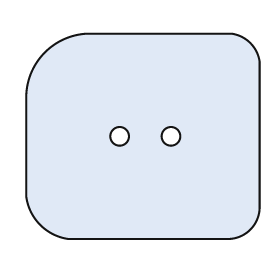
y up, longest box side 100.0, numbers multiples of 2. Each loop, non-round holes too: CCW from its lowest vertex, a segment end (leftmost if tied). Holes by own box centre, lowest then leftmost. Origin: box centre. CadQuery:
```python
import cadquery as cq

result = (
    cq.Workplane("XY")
    .moveTo(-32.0, -44.0)
    .lineTo(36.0, -44.0)
    .threePointArc((46.0, -40.0), (50.0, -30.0))
    .lineTo(50.0, 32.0)
    .threePointArc((46.0, 40.0), (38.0, 44.0))
    .lineTo(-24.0, 44.0)
    .threePointArc((-42.0, 36.0), (-50.0, 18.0))
    .lineTo(-50.0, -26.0)
    .threePointArc((-44.0, -38.0), (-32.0, -44.0))
    .close()
    .moveTo(-10.0, 0.0)
    .circle(4.0)
    .moveTo(12.0, 0.0)
    .circle(4.0)
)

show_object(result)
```